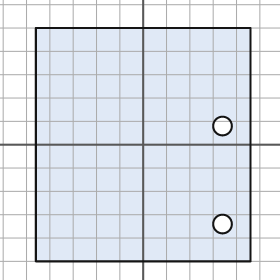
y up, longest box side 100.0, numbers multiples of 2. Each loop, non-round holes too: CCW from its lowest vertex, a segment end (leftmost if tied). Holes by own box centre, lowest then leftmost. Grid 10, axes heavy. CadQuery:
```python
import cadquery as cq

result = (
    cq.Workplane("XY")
    .moveTo(-46.0, -50.0)
    .lineTo(46.0, -50.0)
    .lineTo(46.0, 50.0)
    .lineTo(-46.0, 50.0)
    .close()
    .moveTo(34.0, -34.0)
    .circle(4.0)
    .moveTo(34.0, 8.0)
    .circle(4.0)
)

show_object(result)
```